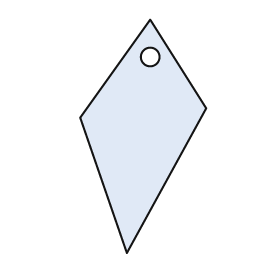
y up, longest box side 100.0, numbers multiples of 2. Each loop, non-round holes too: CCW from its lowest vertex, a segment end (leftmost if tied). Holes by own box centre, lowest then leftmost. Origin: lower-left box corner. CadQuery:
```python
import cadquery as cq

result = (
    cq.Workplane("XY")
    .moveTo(20.0, 0.0)
    .lineTo(54.0, 62.0)
    .lineTo(30.0, 100.0)
    .lineTo(0.0, 58.0)
    .close()
    .moveTo(30.0, 84.0)
    .circle(4.0)
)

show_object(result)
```